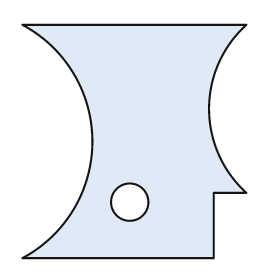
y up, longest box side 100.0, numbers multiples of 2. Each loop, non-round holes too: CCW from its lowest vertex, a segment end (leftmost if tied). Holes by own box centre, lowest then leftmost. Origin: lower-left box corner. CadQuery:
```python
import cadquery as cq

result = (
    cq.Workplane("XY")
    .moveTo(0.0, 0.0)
    .lineTo(82.0, 0.0)
    .lineTo(82.0, 28.0)
    .lineTo(96.0, 28.0)
    .threePointArc((80.0, 64.0), (96.0, 100.0))
    .lineTo(0.0, 100.0)
    .threePointArc((30.0, 50.0), (0.0, 0.0))
    .close()
    .moveTo(46.0, 24.0)
    .circle(8.0)
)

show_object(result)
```